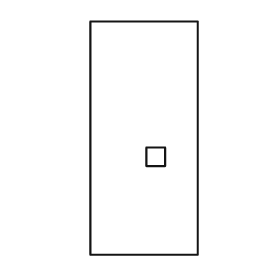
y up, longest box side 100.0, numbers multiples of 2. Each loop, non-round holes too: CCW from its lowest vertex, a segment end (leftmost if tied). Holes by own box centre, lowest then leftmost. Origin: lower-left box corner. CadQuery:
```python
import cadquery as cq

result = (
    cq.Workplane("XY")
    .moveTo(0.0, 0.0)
    .lineTo(46.0, 0.0)
    .lineTo(46.0, 100.0)
    .lineTo(0.0, 100.0)
    .close()
    .moveTo(24.0, 38.0)
    .lineTo(32.0, 38.0)
    .lineTo(32.0, 46.0)
    .lineTo(24.0, 46.0)
    .close()
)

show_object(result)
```